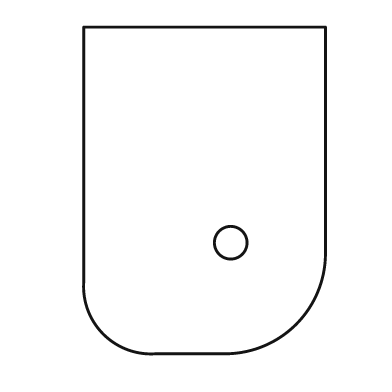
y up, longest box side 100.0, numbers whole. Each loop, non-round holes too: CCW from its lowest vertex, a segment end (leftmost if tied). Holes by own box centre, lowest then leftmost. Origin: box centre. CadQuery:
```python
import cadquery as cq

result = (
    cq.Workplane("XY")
    .moveTo(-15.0, -50.0)
    .lineTo(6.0, -50.0)
    .threePointArc((28.0, -41.0), (37.0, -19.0))
    .lineTo(37.0, 50.0)
    .lineTo(-37.0, 50.0)
    .lineTo(-37.0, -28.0)
    .threePointArc((-31.0, -44.0), (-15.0, -50.0))
    .close()
    .moveTo(8.0, -16.0)
    .circle(5.0)
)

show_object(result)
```